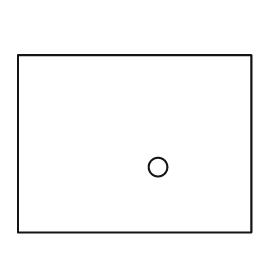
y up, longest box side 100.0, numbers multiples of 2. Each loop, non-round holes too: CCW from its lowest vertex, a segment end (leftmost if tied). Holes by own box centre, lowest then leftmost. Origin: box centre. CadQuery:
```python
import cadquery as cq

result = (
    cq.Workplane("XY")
    .moveTo(-50.0, -38.0)
    .lineTo(50.0, -38.0)
    .lineTo(50.0, 38.0)
    .lineTo(-50.0, 38.0)
    .close()
    .moveTo(10.0, -10.0)
    .circle(4.0)
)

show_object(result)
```